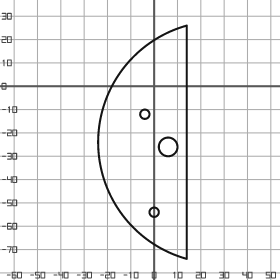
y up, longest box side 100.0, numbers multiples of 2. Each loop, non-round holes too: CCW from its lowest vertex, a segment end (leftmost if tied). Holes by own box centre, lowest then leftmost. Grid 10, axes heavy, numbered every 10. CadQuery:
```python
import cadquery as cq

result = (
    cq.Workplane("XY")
    .moveTo(14.0, -74.0)
    .lineTo(14.0, 26.0)
    .threePointArc((-24.0, -24.0), (14.0, -74.0))
    .close()
    .moveTo(0.0, -54.0)
    .circle(2.0)
    .moveTo(6.0, -26.0)
    .circle(4.0)
    .moveTo(-4.0, -12.0)
    .circle(2.0)
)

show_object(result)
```